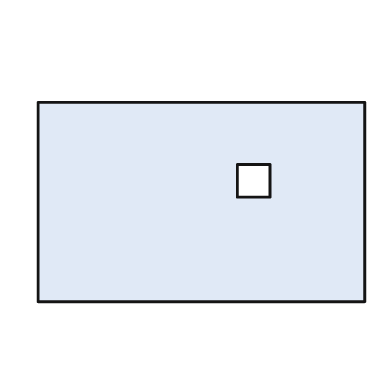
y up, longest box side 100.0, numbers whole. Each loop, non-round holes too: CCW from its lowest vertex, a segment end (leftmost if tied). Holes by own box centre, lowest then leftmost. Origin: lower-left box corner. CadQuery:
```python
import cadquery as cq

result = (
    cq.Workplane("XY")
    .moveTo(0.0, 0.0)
    .lineTo(100.0, 0.0)
    .lineTo(100.0, 61.0)
    .lineTo(0.0, 61.0)
    .close()
    .moveTo(61.0, 32.0)
    .lineTo(71.0, 32.0)
    .lineTo(71.0, 42.0)
    .lineTo(61.0, 42.0)
    .close()
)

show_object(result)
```